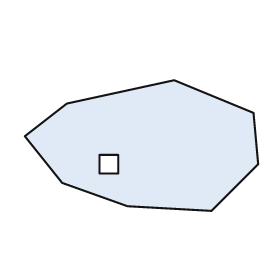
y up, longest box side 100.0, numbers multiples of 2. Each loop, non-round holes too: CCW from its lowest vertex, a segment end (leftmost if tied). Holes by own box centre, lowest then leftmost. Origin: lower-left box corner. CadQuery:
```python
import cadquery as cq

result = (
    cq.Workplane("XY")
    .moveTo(80.0, 0.0)
    .lineTo(100.0, 20.0)
    .lineTo(98.0, 42.0)
    .lineTo(64.0, 56.0)
    .lineTo(18.0, 46.0)
    .lineTo(0.0, 32.0)
    .lineTo(16.0, 12.0)
    .lineTo(44.0, 2.0)
    .close()
    .moveTo(32.0, 16.0)
    .lineTo(40.0, 16.0)
    .lineTo(40.0, 24.0)
    .lineTo(32.0, 24.0)
    .close()
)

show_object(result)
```